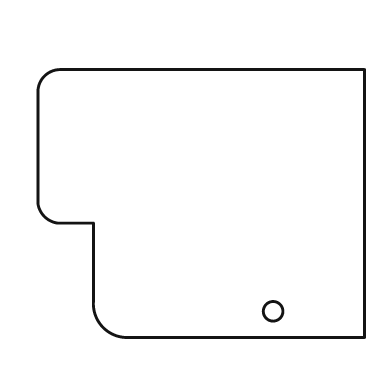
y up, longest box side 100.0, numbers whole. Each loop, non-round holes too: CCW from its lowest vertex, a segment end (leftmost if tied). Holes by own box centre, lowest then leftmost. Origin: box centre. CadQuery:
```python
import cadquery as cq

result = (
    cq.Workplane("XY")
    .moveTo(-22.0, -41.0)
    .lineTo(50.0, -41.0)
    .lineTo(50.0, 41.0)
    .lineTo(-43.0, 41.0)
    .threePointArc((-48.0, 39.0), (-50.0, 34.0))
    .lineTo(-50.0, 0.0)
    .threePointArc((-48.0, -4.0), (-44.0, -6.0))
    .lineTo(-33.0, -6.0)
    .lineTo(-33.0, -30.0)
    .threePointArc((-30.0, -38.0), (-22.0, -41.0))
    .close()
    .moveTo(22.0, -33.0)
    .circle(3.0)
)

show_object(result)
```